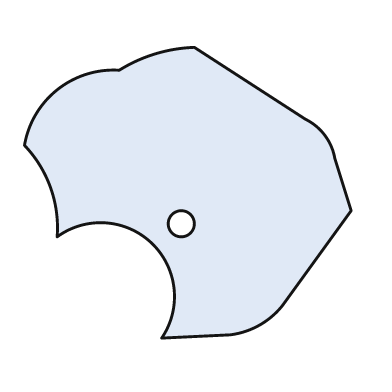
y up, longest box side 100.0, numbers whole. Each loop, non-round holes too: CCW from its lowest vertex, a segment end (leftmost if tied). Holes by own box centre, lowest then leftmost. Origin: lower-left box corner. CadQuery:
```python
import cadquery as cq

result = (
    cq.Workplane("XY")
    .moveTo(42.0, 0.0)
    .lineTo(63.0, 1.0)
    .threePointArc((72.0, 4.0), (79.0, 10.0))
    .lineTo(100.0, 39.0)
    .lineTo(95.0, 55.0)
    .threePointArc((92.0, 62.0), (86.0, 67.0))
    .lineTo(52.0, 89.0)
    .threePointArc((40.0, 87.0), (29.0, 82.0))
    .threePointArc((10.0, 76.0), (0.0, 59.0))
    .threePointArc((8.0, 46.0), (10.0, 31.0))
    .threePointArc((39.0, 29.0), (42.0, 0.0))
    .close()
    .moveTo(48.0, 35.0)
    .circle(4.0)
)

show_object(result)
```